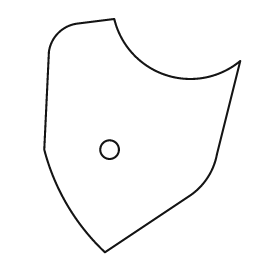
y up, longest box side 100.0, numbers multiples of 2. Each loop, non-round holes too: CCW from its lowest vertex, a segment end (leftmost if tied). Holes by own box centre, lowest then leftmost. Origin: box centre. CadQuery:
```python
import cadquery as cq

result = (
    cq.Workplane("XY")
    .moveTo(-16.0, -50.0)
    .lineTo(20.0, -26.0)
    .threePointArc((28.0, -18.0), (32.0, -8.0))
    .lineTo(42.0, 32.0)
    .threePointArc((10.0, 26.0), (-12.0, 50.0))
    .lineTo(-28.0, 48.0)
    .threePointArc((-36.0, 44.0), (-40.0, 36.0))
    .lineTo(-42.0, -6.0)
    .threePointArc((-32.0, -30.0), (-16.0, -50.0))
    .close()
    .moveTo(-14.0, -6.0)
    .circle(4.0)
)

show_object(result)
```